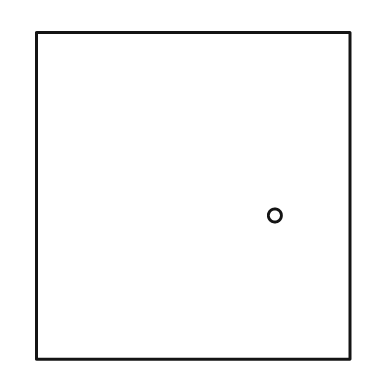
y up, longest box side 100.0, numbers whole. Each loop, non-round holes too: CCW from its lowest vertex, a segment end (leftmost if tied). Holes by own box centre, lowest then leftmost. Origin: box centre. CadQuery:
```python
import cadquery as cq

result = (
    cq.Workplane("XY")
    .moveTo(-48.0, -50.0)
    .lineTo(48.0, -50.0)
    .lineTo(48.0, 50.0)
    .lineTo(-48.0, 50.0)
    .close()
    .moveTo(25.0, -6.0)
    .circle(2.0)
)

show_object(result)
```